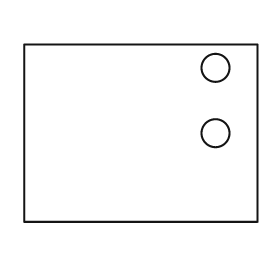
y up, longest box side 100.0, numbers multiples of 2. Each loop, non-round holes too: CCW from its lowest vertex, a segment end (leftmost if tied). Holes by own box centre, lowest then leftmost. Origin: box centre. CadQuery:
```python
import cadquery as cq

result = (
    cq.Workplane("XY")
    .moveTo(-50.0, -38.0)
    .lineTo(50.0, -38.0)
    .lineTo(50.0, 38.0)
    .lineTo(-50.0, 38.0)
    .close()
    .moveTo(32.0, 0.0)
    .circle(6.0)
    .moveTo(32.0, 28.0)
    .circle(6.0)
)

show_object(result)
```